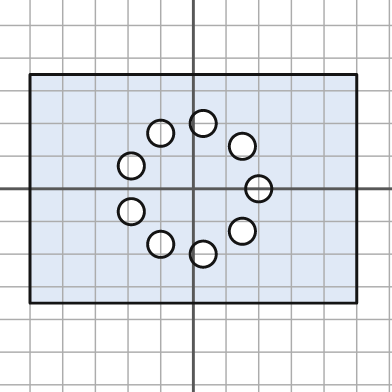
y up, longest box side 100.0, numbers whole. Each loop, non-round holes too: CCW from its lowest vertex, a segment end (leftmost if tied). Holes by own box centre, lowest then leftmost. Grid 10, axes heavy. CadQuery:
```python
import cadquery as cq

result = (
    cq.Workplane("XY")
    .moveTo(-50.0, -35.0)
    .lineTo(50.0, -35.0)
    .lineTo(50.0, 35.0)
    .lineTo(-50.0, 35.0)
    .close()
    .moveTo(3.0, -20.0)
    .circle(4.0)
    .moveTo(-10.0, -17.0)
    .circle(4.0)
    .moveTo(15.0, -13.0)
    .circle(4.0)
    .moveTo(-19.0, -7.0)
    .circle(4.0)
    .moveTo(20.0, 0.0)
    .circle(4.0)
    .moveTo(-19.0, 7.0)
    .circle(4.0)
    .moveTo(15.0, 13.0)
    .circle(4.0)
    .moveTo(-10.0, 17.0)
    .circle(4.0)
    .moveTo(3.0, 20.0)
    .circle(4.0)
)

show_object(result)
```